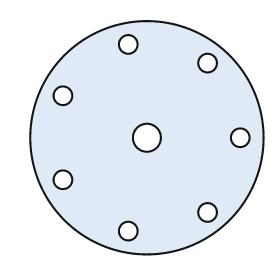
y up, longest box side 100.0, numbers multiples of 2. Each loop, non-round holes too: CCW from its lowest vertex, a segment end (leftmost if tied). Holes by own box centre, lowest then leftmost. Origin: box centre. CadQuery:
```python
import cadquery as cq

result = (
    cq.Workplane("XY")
    .moveTo(0.0, 0.0)
    .circle(50.0)
    .moveTo(-8.0, -40.0)
    .circle(4.0)
    .moveTo(26.0, -32.0)
    .circle(4.0)
    .moveTo(-36.0, -18.0)
    .circle(4.0)
    .moveTo(0.0, 0.0)
    .circle(6.0)
    .moveTo(40.0, 0.0)
    .circle(4.0)
    .moveTo(-36.0, 18.0)
    .circle(4.0)
    .moveTo(26.0, 32.0)
    .circle(4.0)
    .moveTo(-8.0, 40.0)
    .circle(4.0)
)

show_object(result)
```